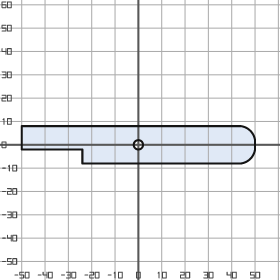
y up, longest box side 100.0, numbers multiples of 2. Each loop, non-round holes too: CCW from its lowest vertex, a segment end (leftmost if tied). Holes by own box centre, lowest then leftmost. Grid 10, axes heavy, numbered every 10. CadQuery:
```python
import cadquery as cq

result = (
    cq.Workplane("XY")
    .moveTo(-24.0, -8.0)
    .lineTo(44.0, -8.0)
    .threePointArc((48.0, -6.0), (50.0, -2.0))
    .lineTo(50.0, 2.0)
    .threePointArc((48.0, 6.0), (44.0, 8.0))
    .lineTo(-50.0, 8.0)
    .lineTo(-50.0, -2.0)
    .lineTo(-24.0, -2.0)
    .close()
    .moveTo(0.0, 0.0)
    .circle(2.0)
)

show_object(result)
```